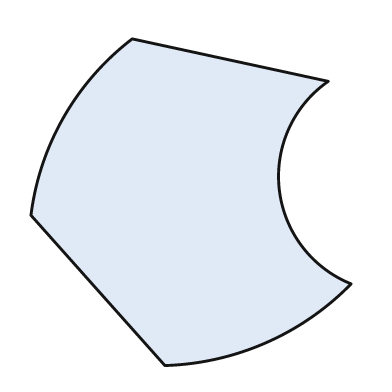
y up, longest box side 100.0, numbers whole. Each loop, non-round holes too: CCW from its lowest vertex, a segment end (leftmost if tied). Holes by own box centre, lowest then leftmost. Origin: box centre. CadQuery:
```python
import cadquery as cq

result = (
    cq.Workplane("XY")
    .moveTo(-8.0, -50.0)
    .threePointArc((23.0, -43.0), (49.0, -25.0))
    .threePointArc((27.0, 4.0), (42.0, 37.0))
    .lineTo(-18.0, 50.0)
    .threePointArc((-39.0, 26.0), (-49.0, -4.0))
    .close()
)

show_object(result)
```